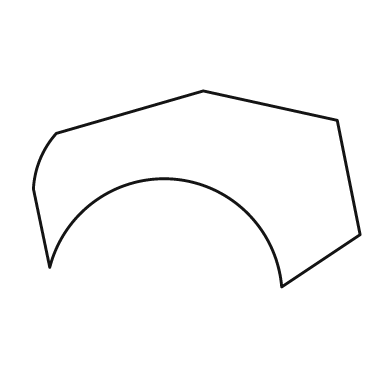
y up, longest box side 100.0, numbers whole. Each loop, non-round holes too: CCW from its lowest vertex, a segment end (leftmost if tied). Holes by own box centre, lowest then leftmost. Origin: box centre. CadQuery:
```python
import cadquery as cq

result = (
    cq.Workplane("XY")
    .moveTo(26.0, -30.0)
    .lineTo(50.0, -14.0)
    .lineTo(43.0, 21.0)
    .lineTo(2.0, 30.0)
    .lineTo(-43.0, 17.0)
    .threePointArc((-48.0, 9.0), (-50.0, 0.0))
    .lineTo(-45.0, -24.0)
    .threePointArc((-7.0, 3.0), (26.0, -30.0))
    .close()
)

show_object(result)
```